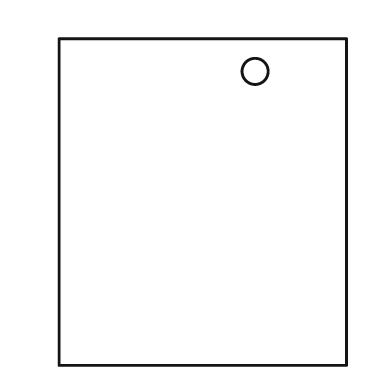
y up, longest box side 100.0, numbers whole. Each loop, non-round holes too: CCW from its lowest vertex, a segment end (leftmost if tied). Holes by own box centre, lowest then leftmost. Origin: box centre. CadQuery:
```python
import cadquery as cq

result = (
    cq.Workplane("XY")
    .moveTo(-44.0, -50.0)
    .lineTo(44.0, -50.0)
    .lineTo(44.0, 50.0)
    .lineTo(-44.0, 50.0)
    .close()
    .moveTo(16.0, 40.0)
    .circle(4.0)
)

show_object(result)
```